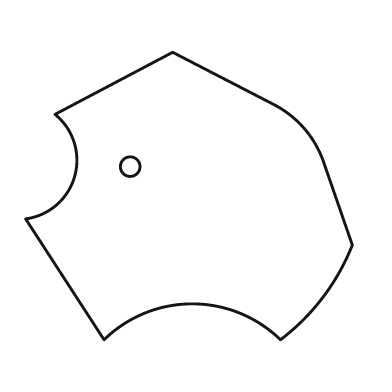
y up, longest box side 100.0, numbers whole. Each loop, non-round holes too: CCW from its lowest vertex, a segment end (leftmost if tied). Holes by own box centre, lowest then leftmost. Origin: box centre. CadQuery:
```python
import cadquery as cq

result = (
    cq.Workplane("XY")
    .moveTo(-26.0, -44.0)
    .threePointArc((1.0, -33.0), (28.0, -44.0))
    .threePointArc((41.0, -31.0), (50.0, -15.0))
    .lineTo(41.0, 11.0)
    .threePointArc((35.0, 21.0), (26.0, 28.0))
    .lineTo(-5.0, 44.0)
    .lineTo(-41.0, 25.0)
    .threePointArc((-35.0, 6.0), (-50.0, -7.0))
    .close()
    .moveTo(-18.0, 9.0)
    .circle(3.0)
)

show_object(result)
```